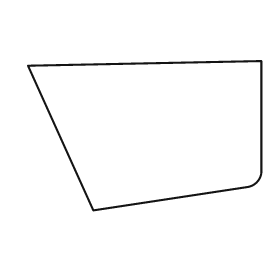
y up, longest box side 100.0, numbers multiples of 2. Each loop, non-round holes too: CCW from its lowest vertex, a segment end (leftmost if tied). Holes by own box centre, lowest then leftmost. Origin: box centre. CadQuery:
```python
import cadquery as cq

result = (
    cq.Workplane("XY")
    .moveTo(-22.0, -32.0)
    .lineTo(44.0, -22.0)
    .threePointArc((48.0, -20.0), (50.0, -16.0))
    .lineTo(50.0, 32.0)
    .lineTo(-50.0, 30.0)
    .close()
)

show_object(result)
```